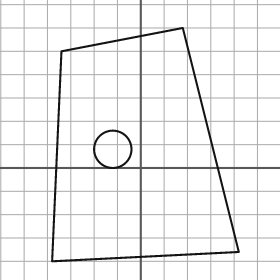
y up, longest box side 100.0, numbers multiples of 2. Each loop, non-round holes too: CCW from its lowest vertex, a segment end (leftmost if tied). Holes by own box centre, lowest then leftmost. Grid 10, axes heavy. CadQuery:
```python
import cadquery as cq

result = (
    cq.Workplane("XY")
    .moveTo(-38.0, -40.0)
    .lineTo(42.0, -36.0)
    .lineTo(18.0, 60.0)
    .lineTo(-34.0, 50.0)
    .close()
    .moveTo(-12.0, 8.0)
    .circle(8.0)
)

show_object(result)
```